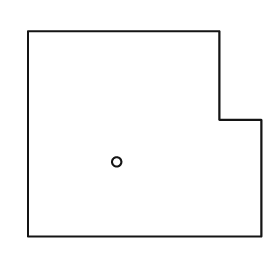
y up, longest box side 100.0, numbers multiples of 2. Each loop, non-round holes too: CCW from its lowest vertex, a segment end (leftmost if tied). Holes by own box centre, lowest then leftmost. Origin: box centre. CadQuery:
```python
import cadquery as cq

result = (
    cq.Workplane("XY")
    .moveTo(-50.0, -44.0)
    .lineTo(50.0, -44.0)
    .lineTo(50.0, 6.0)
    .lineTo(32.0, 6.0)
    .lineTo(32.0, 44.0)
    .lineTo(-50.0, 44.0)
    .close()
    .moveTo(-12.0, -12.0)
    .circle(2.0)
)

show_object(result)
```